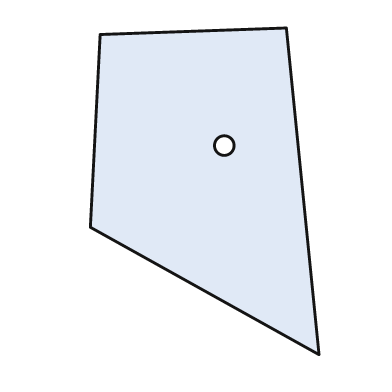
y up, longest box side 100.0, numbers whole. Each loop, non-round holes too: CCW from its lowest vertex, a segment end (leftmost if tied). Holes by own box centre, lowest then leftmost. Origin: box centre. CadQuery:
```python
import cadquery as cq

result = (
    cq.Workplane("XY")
    .moveTo(35.0, -50.0)
    .lineTo(25.0, 50.0)
    .lineTo(-32.0, 48.0)
    .lineTo(-35.0, -11.0)
    .close()
    .moveTo(6.0, 14.0)
    .circle(3.0)
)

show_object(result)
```